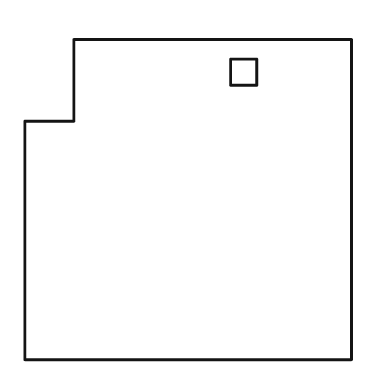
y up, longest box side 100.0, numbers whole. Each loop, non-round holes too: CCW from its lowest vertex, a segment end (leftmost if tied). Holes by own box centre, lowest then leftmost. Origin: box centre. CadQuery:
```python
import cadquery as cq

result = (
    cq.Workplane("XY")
    .moveTo(-50.0, -49.0)
    .lineTo(50.0, -49.0)
    .lineTo(50.0, 49.0)
    .lineTo(-35.0, 49.0)
    .lineTo(-35.0, 24.0)
    .lineTo(-50.0, 24.0)
    .close()
    .moveTo(13.0, 35.0)
    .lineTo(21.0, 35.0)
    .lineTo(21.0, 43.0)
    .lineTo(13.0, 43.0)
    .close()
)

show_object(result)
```